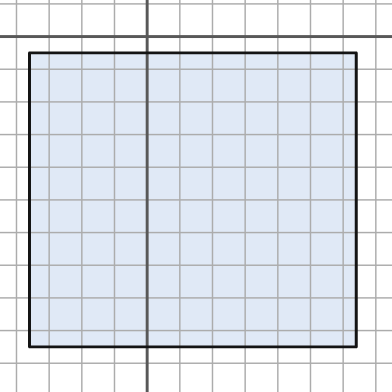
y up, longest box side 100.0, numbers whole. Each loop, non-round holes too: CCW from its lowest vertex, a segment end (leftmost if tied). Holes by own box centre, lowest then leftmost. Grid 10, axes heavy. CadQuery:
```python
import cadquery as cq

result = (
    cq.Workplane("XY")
    .moveTo(-36.0, -95.0)
    .lineTo(64.0, -95.0)
    .lineTo(64.0, -5.0)
    .lineTo(-36.0, -5.0)
    .close()
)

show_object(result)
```